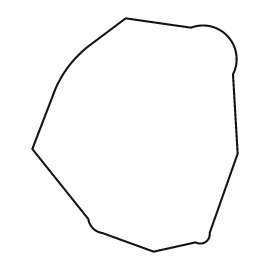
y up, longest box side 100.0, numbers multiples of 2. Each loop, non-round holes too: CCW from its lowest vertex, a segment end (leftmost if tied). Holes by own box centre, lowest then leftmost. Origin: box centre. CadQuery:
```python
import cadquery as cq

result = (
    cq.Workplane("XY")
    .moveTo(8.0, -50.0)
    .lineTo(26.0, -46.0)
    .threePointArc((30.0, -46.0), (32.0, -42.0))
    .lineTo(44.0, -8.0)
    .lineTo(42.0, 26.0)
    .threePointArc((40.0, 42.0), (24.0, 46.0))
    .lineTo(-4.0, 50.0)
    .lineTo(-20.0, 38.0)
    .threePointArc((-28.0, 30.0), (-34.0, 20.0))
    .lineTo(-44.0, -6.0)
    .lineTo(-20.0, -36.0)
    .threePointArc((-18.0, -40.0), (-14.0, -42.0))
    .close()
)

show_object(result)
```